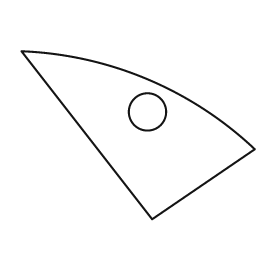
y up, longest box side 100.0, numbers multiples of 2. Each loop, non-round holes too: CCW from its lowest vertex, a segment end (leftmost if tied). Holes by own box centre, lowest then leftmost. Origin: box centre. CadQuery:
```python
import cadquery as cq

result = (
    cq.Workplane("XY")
    .moveTo(6.0, -36.0)
    .lineTo(50.0, -6.0)
    .threePointArc((4.0, 24.0), (-50.0, 36.0))
    .close()
    .moveTo(4.0, 10.0)
    .circle(8.0)
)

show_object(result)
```